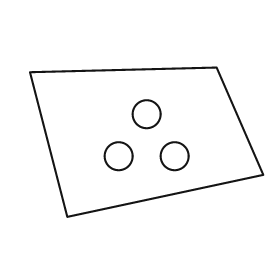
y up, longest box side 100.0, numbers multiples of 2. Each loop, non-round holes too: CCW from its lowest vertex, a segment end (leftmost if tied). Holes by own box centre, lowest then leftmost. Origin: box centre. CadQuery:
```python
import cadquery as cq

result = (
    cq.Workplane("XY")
    .moveTo(-34.0, -32.0)
    .lineTo(50.0, -14.0)
    .lineTo(30.0, 32.0)
    .lineTo(-50.0, 30.0)
    .close()
    .moveTo(-12.0, -6.0)
    .circle(6.0)
    .moveTo(12.0, -6.0)
    .circle(6.0)
    .moveTo(0.0, 12.0)
    .circle(6.0)
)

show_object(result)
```